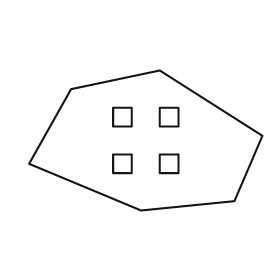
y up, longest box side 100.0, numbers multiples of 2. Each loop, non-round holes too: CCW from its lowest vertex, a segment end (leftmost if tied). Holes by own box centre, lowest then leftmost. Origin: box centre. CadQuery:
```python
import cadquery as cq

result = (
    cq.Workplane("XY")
    .moveTo(-2.0, -30.0)
    .lineTo(38.0, -26.0)
    .lineTo(50.0, 2.0)
    .lineTo(6.0, 30.0)
    .lineTo(-32.0, 22.0)
    .lineTo(-50.0, -10.0)
    .close()
    .moveTo(-14.0, -14.0)
    .lineTo(-6.0, -14.0)
    .lineTo(-6.0, -6.0)
    .lineTo(-14.0, -6.0)
    .close()
    .moveTo(6.0, -14.0)
    .lineTo(14.0, -14.0)
    .lineTo(14.0, -6.0)
    .lineTo(6.0, -6.0)
    .close()
    .moveTo(-14.0, 6.0)
    .lineTo(-6.0, 6.0)
    .lineTo(-6.0, 14.0)
    .lineTo(-14.0, 14.0)
    .close()
    .moveTo(6.0, 6.0)
    .lineTo(14.0, 6.0)
    .lineTo(14.0, 14.0)
    .lineTo(6.0, 14.0)
    .close()
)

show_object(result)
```